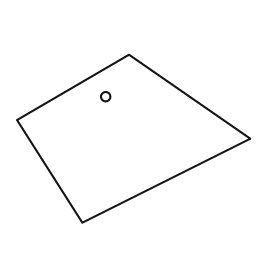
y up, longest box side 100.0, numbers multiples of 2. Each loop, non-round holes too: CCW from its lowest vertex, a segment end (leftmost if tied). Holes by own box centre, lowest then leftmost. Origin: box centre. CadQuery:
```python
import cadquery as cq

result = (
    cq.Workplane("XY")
    .moveTo(-22.0, -36.0)
    .lineTo(50.0, 0.0)
    .lineTo(-2.0, 36.0)
    .lineTo(-50.0, 8.0)
    .close()
    .moveTo(-12.0, 18.0)
    .circle(2.0)
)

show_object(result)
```